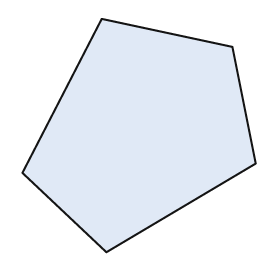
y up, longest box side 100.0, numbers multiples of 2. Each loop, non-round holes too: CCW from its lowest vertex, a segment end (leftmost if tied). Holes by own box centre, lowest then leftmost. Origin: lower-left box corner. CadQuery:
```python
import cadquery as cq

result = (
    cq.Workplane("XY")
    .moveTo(36.0, 0.0)
    .lineTo(100.0, 38.0)
    .lineTo(90.0, 88.0)
    .lineTo(34.0, 100.0)
    .lineTo(0.0, 34.0)
    .close()
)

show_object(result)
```